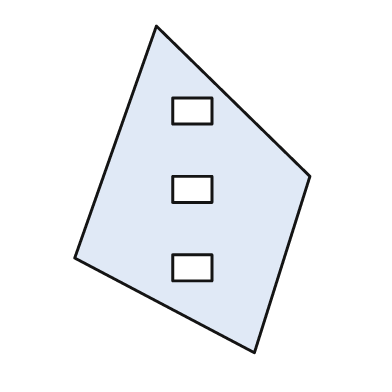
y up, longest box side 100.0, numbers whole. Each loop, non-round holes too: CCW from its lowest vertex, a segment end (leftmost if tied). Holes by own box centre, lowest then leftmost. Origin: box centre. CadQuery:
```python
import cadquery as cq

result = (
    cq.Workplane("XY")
    .moveTo(19.0, -50.0)
    .lineTo(36.0, 4.0)
    .lineTo(-11.0, 50.0)
    .lineTo(-36.0, -21.0)
    .close()
    .moveTo(-6.0, -28.0)
    .lineTo(6.0, -28.0)
    .lineTo(6.0, -20.0)
    .lineTo(-6.0, -20.0)
    .close()
    .moveTo(-6.0, -4.0)
    .lineTo(6.0, -4.0)
    .lineTo(6.0, 4.0)
    .lineTo(-6.0, 4.0)
    .close()
    .moveTo(-6.0, 20.0)
    .lineTo(6.0, 20.0)
    .lineTo(6.0, 28.0)
    .lineTo(-6.0, 28.0)
    .close()
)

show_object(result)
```